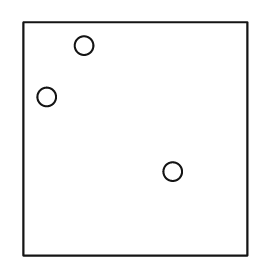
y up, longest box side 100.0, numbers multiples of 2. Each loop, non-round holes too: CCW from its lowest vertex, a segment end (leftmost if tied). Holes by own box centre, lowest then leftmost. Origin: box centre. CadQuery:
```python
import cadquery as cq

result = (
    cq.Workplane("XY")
    .moveTo(-48.0, -50.0)
    .lineTo(48.0, -50.0)
    .lineTo(48.0, 50.0)
    .lineTo(-48.0, 50.0)
    .close()
    .moveTo(16.0, -14.0)
    .circle(4.0)
    .moveTo(-38.0, 18.0)
    .circle(4.0)
    .moveTo(-22.0, 40.0)
    .circle(4.0)
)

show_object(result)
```